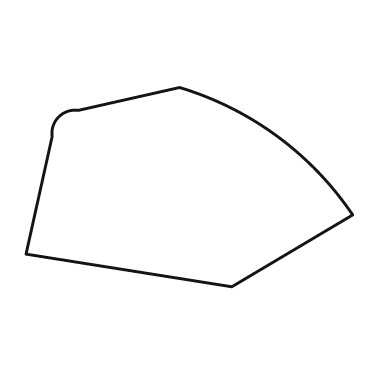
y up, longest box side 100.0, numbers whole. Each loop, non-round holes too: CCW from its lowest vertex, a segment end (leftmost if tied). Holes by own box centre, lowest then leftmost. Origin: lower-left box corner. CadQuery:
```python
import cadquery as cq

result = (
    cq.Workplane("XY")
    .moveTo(63.0, 0.0)
    .lineTo(100.0, 22.0)
    .threePointArc((77.0, 46.0), (47.0, 61.0))
    .lineTo(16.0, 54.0)
    .threePointArc((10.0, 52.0), (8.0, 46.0))
    .lineTo(0.0, 10.0)
    .close()
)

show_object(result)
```